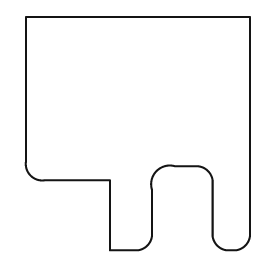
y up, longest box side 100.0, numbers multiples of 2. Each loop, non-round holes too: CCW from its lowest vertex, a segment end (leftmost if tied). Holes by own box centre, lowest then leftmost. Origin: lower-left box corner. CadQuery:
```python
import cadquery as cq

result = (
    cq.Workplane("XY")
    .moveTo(36.0, 0.0)
    .lineTo(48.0, 0.0)
    .threePointArc((52.0, 2.0), (54.0, 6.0))
    .lineTo(54.0, 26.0)
    .threePointArc((56.0, 34.0), (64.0, 36.0))
    .lineTo(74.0, 36.0)
    .threePointArc((78.0, 34.0), (80.0, 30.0))
    .lineTo(80.0, 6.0)
    .threePointArc((82.0, 2.0), (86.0, 0.0))
    .lineTo(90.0, 0.0)
    .threePointArc((94.0, 2.0), (96.0, 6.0))
    .lineTo(96.0, 100.0)
    .lineTo(0.0, 100.0)
    .lineTo(0.0, 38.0)
    .threePointArc((2.0, 32.0), (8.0, 30.0))
    .lineTo(36.0, 30.0)
    .close()
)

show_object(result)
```